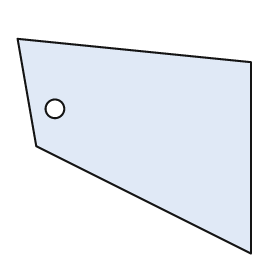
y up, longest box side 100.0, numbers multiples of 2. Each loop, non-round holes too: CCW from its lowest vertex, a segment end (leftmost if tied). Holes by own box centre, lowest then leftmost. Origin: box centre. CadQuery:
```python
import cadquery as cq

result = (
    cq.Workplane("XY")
    .moveTo(50.0, -46.0)
    .lineTo(50.0, 36.0)
    .lineTo(-50.0, 46.0)
    .lineTo(-42.0, 0.0)
    .close()
    .moveTo(-34.0, 16.0)
    .circle(4.0)
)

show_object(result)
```